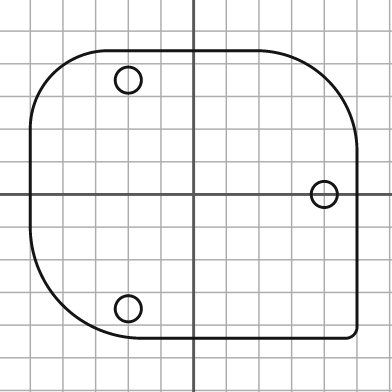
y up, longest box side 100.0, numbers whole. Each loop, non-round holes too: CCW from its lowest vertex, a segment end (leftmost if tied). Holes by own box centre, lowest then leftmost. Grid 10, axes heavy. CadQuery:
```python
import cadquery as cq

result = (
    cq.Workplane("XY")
    .moveTo(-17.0, -44.0)
    .lineTo(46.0, -44.0)
    .threePointArc((49.0, -43.0), (50.0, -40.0))
    .lineTo(50.0, 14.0)
    .threePointArc((41.0, 35.0), (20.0, 44.0))
    .lineTo(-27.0, 44.0)
    .threePointArc((-43.0, 37.0), (-50.0, 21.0))
    .lineTo(-50.0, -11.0)
    .threePointArc((-40.0, -34.0), (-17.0, -44.0))
    .close()
    .moveTo(-20.0, -35.0)
    .circle(4.0)
    .moveTo(40.0, 0.0)
    .circle(4.0)
    .moveTo(-20.0, 35.0)
    .circle(4.0)
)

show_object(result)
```